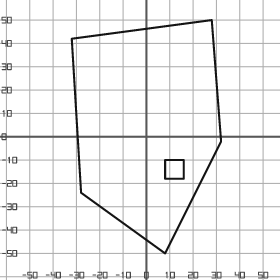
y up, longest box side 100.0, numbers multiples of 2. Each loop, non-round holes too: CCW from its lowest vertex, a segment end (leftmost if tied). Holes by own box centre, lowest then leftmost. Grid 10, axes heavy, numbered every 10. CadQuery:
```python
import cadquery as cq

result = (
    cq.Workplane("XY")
    .moveTo(8.0, -50.0)
    .lineTo(32.0, -2.0)
    .lineTo(28.0, 50.0)
    .lineTo(-32.0, 42.0)
    .lineTo(-28.0, -24.0)
    .close()
    .moveTo(8.0, -18.0)
    .lineTo(16.0, -18.0)
    .lineTo(16.0, -10.0)
    .lineTo(8.0, -10.0)
    .close()
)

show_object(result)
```